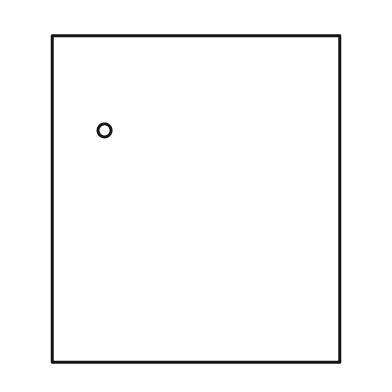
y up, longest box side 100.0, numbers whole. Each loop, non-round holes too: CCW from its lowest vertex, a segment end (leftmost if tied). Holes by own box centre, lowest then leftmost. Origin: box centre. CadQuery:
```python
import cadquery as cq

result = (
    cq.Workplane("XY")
    .moveTo(-44.0, -50.0)
    .lineTo(44.0, -50.0)
    .lineTo(44.0, 50.0)
    .lineTo(-44.0, 50.0)
    .close()
    .moveTo(-28.0, 21.0)
    .circle(2.0)
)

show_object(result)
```